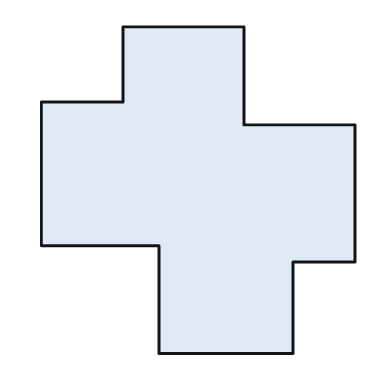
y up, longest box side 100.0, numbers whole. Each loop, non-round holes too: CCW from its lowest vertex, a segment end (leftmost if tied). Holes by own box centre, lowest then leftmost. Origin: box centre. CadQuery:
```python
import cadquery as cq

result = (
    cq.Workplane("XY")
    .moveTo(-12.0, -50.0)
    .lineTo(29.0, -50.0)
    .lineTo(29.0, -22.0)
    .lineTo(48.0, -22.0)
    .lineTo(48.0, 20.0)
    .lineTo(14.0, 20.0)
    .lineTo(14.0, 50.0)
    .lineTo(-23.0, 50.0)
    .lineTo(-23.0, 27.0)
    .lineTo(-48.0, 27.0)
    .lineTo(-48.0, -17.0)
    .lineTo(-12.0, -17.0)
    .close()
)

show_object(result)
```